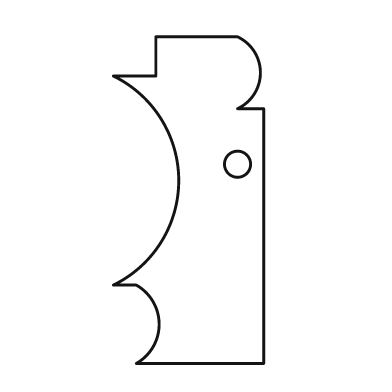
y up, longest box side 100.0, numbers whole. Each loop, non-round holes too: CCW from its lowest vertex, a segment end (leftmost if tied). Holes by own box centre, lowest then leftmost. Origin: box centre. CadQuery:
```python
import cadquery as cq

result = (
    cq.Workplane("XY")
    .moveTo(-16.0, -50.0)
    .lineTo(23.0, -50.0)
    .lineTo(23.0, 28.0)
    .lineTo(15.0, 28.0)
    .threePointArc((22.0, 39.0), (15.0, 50.0))
    .lineTo(-10.0, 50.0)
    .lineTo(-10.0, 38.0)
    .lineTo(-23.0, 38.0)
    .threePointArc((-3.0, 6.0), (-23.0, -26.0))
    .lineTo(-16.0, -26.0)
    .threePointArc((-9.0, -38.0), (-16.0, -50.0))
    .close()
    .moveTo(15.0, 11.0)
    .circle(4.0)
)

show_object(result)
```